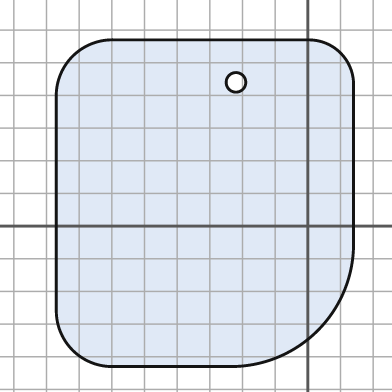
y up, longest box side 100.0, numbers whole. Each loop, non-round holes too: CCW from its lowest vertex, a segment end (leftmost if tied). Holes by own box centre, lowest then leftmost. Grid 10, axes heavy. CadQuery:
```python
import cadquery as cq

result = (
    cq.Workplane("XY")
    .moveTo(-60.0, -43.0)
    .lineTo(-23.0, -43.0)
    .threePointArc((3.0, -32.0), (14.0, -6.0))
    .lineTo(14.0, 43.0)
    .threePointArc((10.0, 53.0), (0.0, 57.0))
    .lineTo(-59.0, 57.0)
    .threePointArc((-72.0, 52.0), (-77.0, 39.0))
    .lineTo(-77.0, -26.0)
    .threePointArc((-72.0, -38.0), (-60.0, -43.0))
    .close()
    .moveTo(-22.0, 44.0)
    .circle(3.0)
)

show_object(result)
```